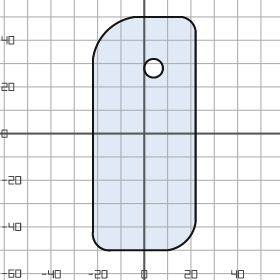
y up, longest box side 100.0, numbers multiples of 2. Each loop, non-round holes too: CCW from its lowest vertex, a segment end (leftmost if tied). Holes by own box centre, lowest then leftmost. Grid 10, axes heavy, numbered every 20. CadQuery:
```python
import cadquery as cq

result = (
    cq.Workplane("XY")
    .moveTo(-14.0, -50.0)
    .lineTo(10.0, -50.0)
    .threePointArc((18.0, -46.0), (22.0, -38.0))
    .lineTo(22.0, 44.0)
    .threePointArc((20.0, 48.0), (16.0, 50.0))
    .lineTo(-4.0, 50.0)
    .threePointArc((-16.0, 44.0), (-22.0, 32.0))
    .lineTo(-22.0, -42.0)
    .threePointArc((-20.0, -48.0), (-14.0, -50.0))
    .close()
    .moveTo(4.0, 28.0)
    .circle(4.0)
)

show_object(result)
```